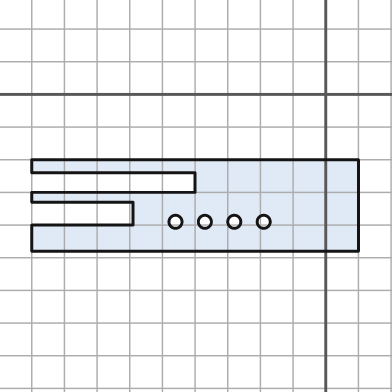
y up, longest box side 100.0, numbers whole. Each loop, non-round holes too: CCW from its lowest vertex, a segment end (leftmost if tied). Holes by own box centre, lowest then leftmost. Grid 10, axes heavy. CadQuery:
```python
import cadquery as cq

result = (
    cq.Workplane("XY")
    .moveTo(-90.0, -48.0)
    .lineTo(10.0, -48.0)
    .lineTo(10.0, -20.0)
    .lineTo(-90.0, -20.0)
    .lineTo(-90.0, -24.0)
    .lineTo(-40.0, -24.0)
    .lineTo(-40.0, -30.0)
    .lineTo(-90.0, -30.0)
    .lineTo(-90.0, -33.0)
    .lineTo(-59.0, -33.0)
    .lineTo(-59.0, -40.0)
    .lineTo(-90.0, -40.0)
    .close()
    .moveTo(-46.0, -39.0)
    .circle(2.0)
    .moveTo(-37.0, -39.0)
    .circle(2.0)
    .moveTo(-28.0, -39.0)
    .circle(2.0)
    .moveTo(-19.0, -39.0)
    .circle(2.0)
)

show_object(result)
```